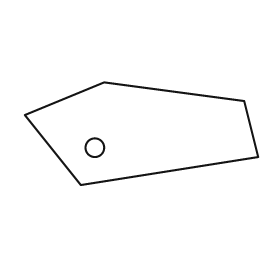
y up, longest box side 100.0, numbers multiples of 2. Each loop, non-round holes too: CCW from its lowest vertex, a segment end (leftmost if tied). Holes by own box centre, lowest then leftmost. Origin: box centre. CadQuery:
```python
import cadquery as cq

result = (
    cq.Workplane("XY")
    .moveTo(-26.0, -22.0)
    .lineTo(50.0, -10.0)
    .lineTo(44.0, 14.0)
    .lineTo(-16.0, 22.0)
    .lineTo(-50.0, 8.0)
    .close()
    .moveTo(-20.0, -6.0)
    .circle(4.0)
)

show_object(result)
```